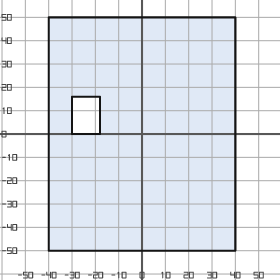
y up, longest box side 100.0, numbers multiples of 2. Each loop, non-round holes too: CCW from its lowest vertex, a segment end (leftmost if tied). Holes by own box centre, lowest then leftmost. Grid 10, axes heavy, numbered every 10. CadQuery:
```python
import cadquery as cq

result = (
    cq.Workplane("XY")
    .moveTo(-40.0, -50.0)
    .lineTo(40.0, -50.0)
    .lineTo(40.0, 50.0)
    .lineTo(-40.0, 50.0)
    .close()
    .moveTo(-30.0, 0.0)
    .lineTo(-18.0, 0.0)
    .lineTo(-18.0, 16.0)
    .lineTo(-30.0, 16.0)
    .close()
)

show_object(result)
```